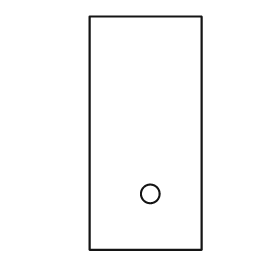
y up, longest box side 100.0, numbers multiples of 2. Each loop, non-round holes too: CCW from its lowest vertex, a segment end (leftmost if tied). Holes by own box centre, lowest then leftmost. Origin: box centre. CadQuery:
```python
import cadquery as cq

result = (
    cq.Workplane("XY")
    .moveTo(-24.0, -50.0)
    .lineTo(24.0, -50.0)
    .lineTo(24.0, 50.0)
    .lineTo(-24.0, 50.0)
    .close()
    .moveTo(2.0, -26.0)
    .circle(4.0)
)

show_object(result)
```